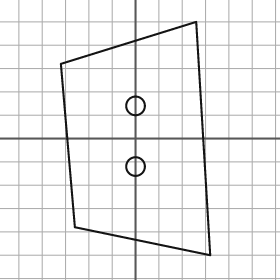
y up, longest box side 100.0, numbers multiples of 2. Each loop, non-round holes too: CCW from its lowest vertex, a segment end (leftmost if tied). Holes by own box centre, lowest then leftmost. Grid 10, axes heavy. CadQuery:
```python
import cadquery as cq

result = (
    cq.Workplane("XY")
    .moveTo(32.0, -50.0)
    .lineTo(26.0, 50.0)
    .lineTo(-32.0, 32.0)
    .lineTo(-26.0, -38.0)
    .close()
    .moveTo(0.0, -12.0)
    .circle(4.0)
    .moveTo(0.0, 14.0)
    .circle(4.0)
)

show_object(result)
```